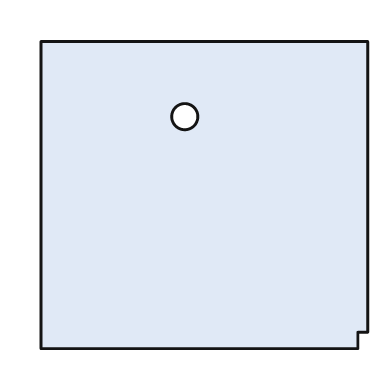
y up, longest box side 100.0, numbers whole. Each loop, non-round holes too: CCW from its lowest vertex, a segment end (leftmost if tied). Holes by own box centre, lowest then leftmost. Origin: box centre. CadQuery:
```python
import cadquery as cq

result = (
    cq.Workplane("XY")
    .moveTo(-50.0, -47.0)
    .lineTo(47.0, -47.0)
    .lineTo(47.0, -42.0)
    .lineTo(50.0, -42.0)
    .lineTo(50.0, 47.0)
    .lineTo(-50.0, 47.0)
    .close()
    .moveTo(-6.0, 24.0)
    .circle(4.0)
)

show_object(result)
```